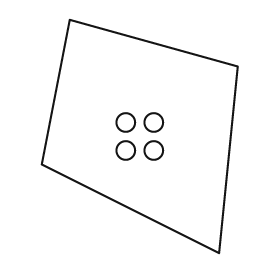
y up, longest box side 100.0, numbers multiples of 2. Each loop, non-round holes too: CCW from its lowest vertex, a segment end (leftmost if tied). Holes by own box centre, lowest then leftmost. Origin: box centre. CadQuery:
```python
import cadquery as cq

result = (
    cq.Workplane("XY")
    .moveTo(34.0, -50.0)
    .lineTo(42.0, 30.0)
    .lineTo(-30.0, 50.0)
    .lineTo(-42.0, -12.0)
    .close()
    .moveTo(-6.0, -6.0)
    .circle(4.0)
    .moveTo(6.0, -6.0)
    .circle(4.0)
    .moveTo(-6.0, 6.0)
    .circle(4.0)
    .moveTo(6.0, 6.0)
    .circle(4.0)
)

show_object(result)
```